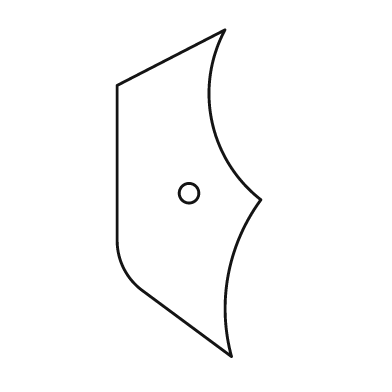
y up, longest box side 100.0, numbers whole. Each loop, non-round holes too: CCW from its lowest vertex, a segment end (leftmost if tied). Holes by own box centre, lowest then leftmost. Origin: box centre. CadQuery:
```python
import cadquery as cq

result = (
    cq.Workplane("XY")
    .moveTo(13.0, -50.0)
    .threePointArc((12.0, -25.0), (22.0, -2.0))
    .threePointArc((7.0, 22.0), (11.0, 50.0))
    .lineTo(-22.0, 33.0)
    .lineTo(-22.0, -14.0)
    .threePointArc((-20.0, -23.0), (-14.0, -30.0))
    .close()
    .moveTo(0.0, 0.0)
    .circle(3.0)
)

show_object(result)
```